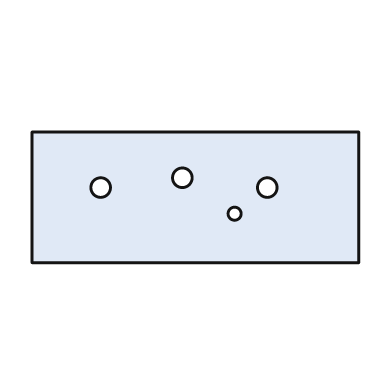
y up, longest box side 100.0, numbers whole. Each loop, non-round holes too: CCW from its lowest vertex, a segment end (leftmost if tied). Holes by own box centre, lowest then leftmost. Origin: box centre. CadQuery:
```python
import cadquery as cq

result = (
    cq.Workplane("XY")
    .moveTo(-50.0, -20.0)
    .lineTo(50.0, -20.0)
    .lineTo(50.0, 20.0)
    .lineTo(-50.0, 20.0)
    .close()
    .moveTo(12.0, -5.0)
    .circle(2.0)
    .moveTo(-29.0, 3.0)
    .circle(3.0)
    .moveTo(22.0, 3.0)
    .circle(3.0)
    .moveTo(-4.0, 6.0)
    .circle(3.0)
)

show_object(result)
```